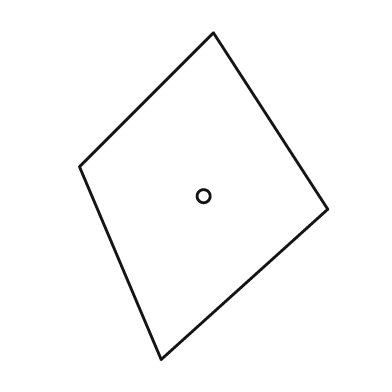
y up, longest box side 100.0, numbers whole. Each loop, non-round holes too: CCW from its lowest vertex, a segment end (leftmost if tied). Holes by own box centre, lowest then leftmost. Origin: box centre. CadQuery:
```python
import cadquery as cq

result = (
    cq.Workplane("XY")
    .moveTo(-13.0, -50.0)
    .lineTo(38.0, -4.0)
    .lineTo(3.0, 50.0)
    .lineTo(-38.0, 9.0)
    .close()
    .moveTo(0.0, 0.0)
    .circle(2.0)
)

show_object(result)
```